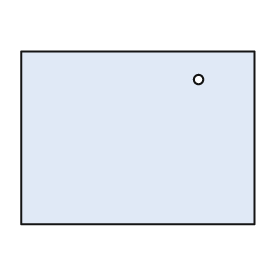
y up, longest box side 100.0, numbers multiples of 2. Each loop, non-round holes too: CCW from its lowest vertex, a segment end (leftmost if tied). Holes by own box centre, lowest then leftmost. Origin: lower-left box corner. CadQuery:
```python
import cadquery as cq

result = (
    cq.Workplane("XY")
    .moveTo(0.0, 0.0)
    .lineTo(100.0, 0.0)
    .lineTo(100.0, 74.0)
    .lineTo(0.0, 74.0)
    .close()
    .moveTo(76.0, 62.0)
    .circle(2.0)
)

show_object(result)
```